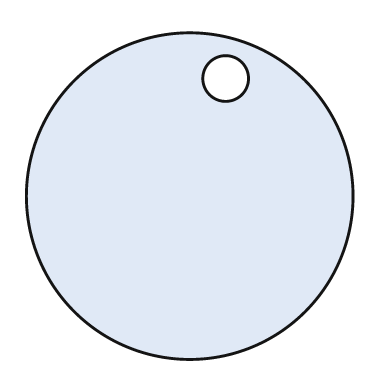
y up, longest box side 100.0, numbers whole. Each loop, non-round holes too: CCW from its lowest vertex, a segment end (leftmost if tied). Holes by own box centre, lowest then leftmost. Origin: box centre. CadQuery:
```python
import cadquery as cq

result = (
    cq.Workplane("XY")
    .moveTo(0.0, 0.0)
    .circle(50.0)
    .moveTo(11.0, 36.0)
    .circle(7.0)
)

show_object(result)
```